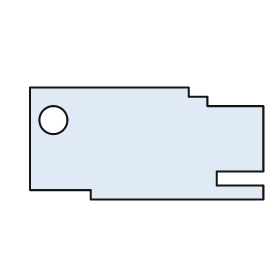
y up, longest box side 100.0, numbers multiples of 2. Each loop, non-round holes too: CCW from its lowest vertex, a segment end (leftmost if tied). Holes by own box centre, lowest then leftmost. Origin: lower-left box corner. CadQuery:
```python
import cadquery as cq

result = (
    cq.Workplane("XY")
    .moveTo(26.0, 0.0)
    .lineTo(100.0, 0.0)
    .lineTo(100.0, 6.0)
    .lineTo(80.0, 6.0)
    .lineTo(80.0, 12.0)
    .lineTo(100.0, 12.0)
    .lineTo(100.0, 40.0)
    .lineTo(76.0, 40.0)
    .lineTo(76.0, 44.0)
    .lineTo(68.0, 44.0)
    .lineTo(68.0, 48.0)
    .lineTo(0.0, 48.0)
    .lineTo(0.0, 4.0)
    .lineTo(26.0, 4.0)
    .close()
    .moveTo(10.0, 34.0)
    .circle(6.0)
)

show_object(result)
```